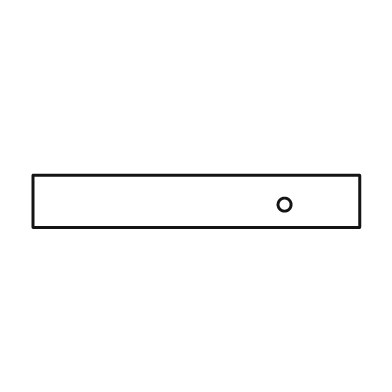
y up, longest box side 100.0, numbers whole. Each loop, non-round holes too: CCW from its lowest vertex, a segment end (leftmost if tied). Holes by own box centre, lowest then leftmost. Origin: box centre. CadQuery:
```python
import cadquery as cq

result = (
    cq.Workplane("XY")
    .moveTo(-50.0, -8.0)
    .lineTo(50.0, -8.0)
    .lineTo(50.0, 8.0)
    .lineTo(-50.0, 8.0)
    .close()
    .moveTo(27.0, -1.0)
    .circle(2.0)
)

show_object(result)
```